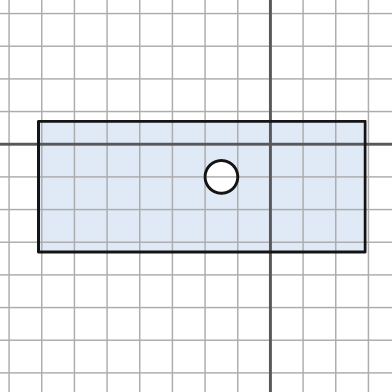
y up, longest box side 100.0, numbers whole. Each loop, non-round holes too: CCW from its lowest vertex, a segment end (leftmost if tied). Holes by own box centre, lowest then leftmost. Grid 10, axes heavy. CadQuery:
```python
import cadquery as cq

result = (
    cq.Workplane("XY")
    .moveTo(-71.0, -33.0)
    .lineTo(29.0, -33.0)
    .lineTo(29.0, 7.0)
    .lineTo(-71.0, 7.0)
    .close()
    .moveTo(-15.0, -10.0)
    .circle(5.0)
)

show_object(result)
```